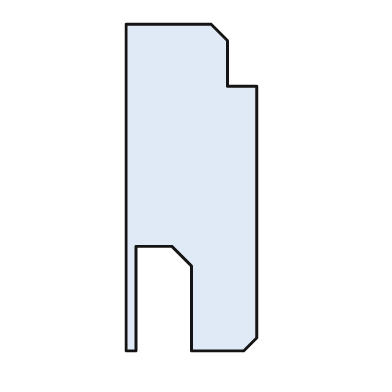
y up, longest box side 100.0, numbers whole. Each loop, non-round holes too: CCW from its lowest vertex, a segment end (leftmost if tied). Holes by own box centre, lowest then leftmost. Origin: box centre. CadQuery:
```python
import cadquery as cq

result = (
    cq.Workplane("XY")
    .moveTo(-20.0, -50.0)
    .lineTo(-17.0, -50.0)
    .lineTo(-17.0, -18.0)
    .lineTo(-6.0, -18.0)
    .lineTo(0.0, -24.0)
    .lineTo(0.0, -50.0)
    .lineTo(16.0, -50.0)
    .lineTo(20.0, -46.0)
    .lineTo(20.0, 31.0)
    .lineTo(11.0, 31.0)
    .lineTo(11.0, 45.0)
    .lineTo(6.0, 50.0)
    .lineTo(-20.0, 50.0)
    .close()
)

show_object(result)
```